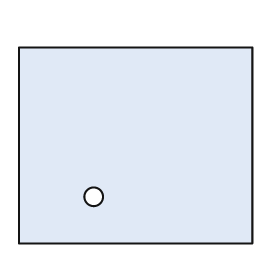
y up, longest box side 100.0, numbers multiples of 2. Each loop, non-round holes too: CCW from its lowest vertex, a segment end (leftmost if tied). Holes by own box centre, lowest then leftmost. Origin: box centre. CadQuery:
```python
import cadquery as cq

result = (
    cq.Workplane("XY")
    .moveTo(-50.0, -42.0)
    .lineTo(50.0, -42.0)
    .lineTo(50.0, 42.0)
    .lineTo(-50.0, 42.0)
    .close()
    .moveTo(-18.0, -22.0)
    .circle(4.0)
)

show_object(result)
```